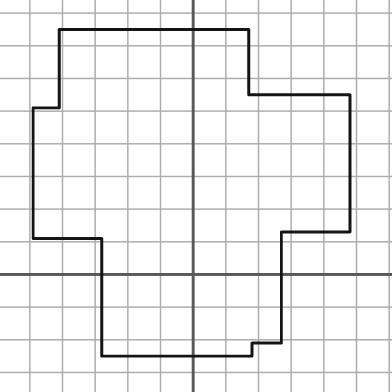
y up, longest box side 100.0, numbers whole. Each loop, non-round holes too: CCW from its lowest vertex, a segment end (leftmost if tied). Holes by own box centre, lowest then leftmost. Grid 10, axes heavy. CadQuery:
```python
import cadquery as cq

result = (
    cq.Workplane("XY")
    .moveTo(-28.0, -25.0)
    .lineTo(18.0, -25.0)
    .lineTo(18.0, -21.0)
    .lineTo(27.0, -21.0)
    .lineTo(27.0, 13.0)
    .lineTo(48.0, 13.0)
    .lineTo(48.0, 55.0)
    .lineTo(17.0, 55.0)
    .lineTo(17.0, 75.0)
    .lineTo(-41.0, 75.0)
    .lineTo(-41.0, 51.0)
    .lineTo(-49.0, 51.0)
    .lineTo(-49.0, 11.0)
    .lineTo(-28.0, 11.0)
    .close()
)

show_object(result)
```